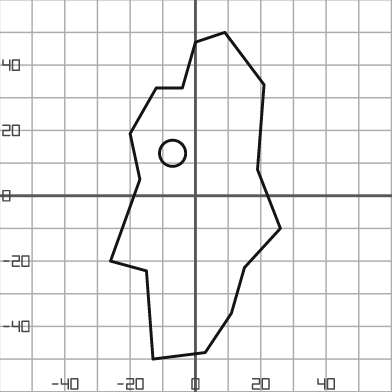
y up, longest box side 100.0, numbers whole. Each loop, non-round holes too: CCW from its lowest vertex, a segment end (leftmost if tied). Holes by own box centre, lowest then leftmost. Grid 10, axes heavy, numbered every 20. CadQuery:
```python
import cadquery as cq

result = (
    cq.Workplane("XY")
    .moveTo(-13.0, -50.0)
    .lineTo(3.0, -48.0)
    .lineTo(11.0, -36.0)
    .lineTo(15.0, -22.0)
    .lineTo(26.0, -10.0)
    .lineTo(19.0, 8.0)
    .lineTo(21.0, 34.0)
    .lineTo(9.0, 50.0)
    .lineTo(0.0, 47.0)
    .lineTo(-4.0, 33.0)
    .lineTo(-12.0, 33.0)
    .lineTo(-20.0, 19.0)
    .lineTo(-17.0, 5.0)
    .lineTo(-26.0, -20.0)
    .lineTo(-15.0, -23.0)
    .close()
    .moveTo(-7.0, 13.0)
    .circle(4.0)
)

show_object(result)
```